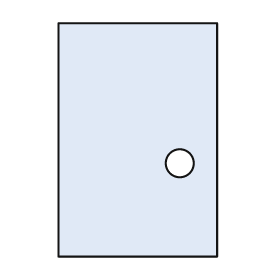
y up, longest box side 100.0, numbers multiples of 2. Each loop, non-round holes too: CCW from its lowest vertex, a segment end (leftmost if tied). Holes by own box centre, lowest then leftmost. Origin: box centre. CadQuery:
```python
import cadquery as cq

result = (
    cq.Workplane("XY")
    .moveTo(-34.0, -50.0)
    .lineTo(34.0, -50.0)
    .lineTo(34.0, 50.0)
    .lineTo(-34.0, 50.0)
    .close()
    .moveTo(18.0, -10.0)
    .circle(6.0)
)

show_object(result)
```